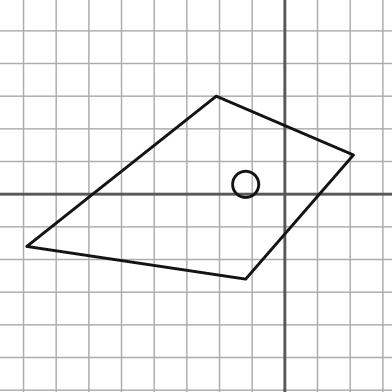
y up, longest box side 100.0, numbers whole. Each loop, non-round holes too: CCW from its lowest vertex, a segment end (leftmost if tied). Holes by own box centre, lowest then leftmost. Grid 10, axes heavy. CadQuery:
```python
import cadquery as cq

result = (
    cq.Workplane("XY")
    .moveTo(-12.0, -26.0)
    .lineTo(21.0, 12.0)
    .lineTo(-21.0, 30.0)
    .lineTo(-79.0, -16.0)
    .close()
    .moveTo(-12.0, 3.0)
    .circle(4.0)
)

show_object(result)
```